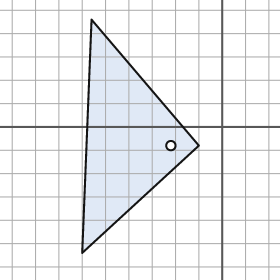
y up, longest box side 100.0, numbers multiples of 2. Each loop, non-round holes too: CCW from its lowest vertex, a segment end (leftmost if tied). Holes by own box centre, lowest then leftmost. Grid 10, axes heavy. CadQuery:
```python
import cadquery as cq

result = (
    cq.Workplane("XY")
    .moveTo(-60.0, -54.0)
    .lineTo(-10.0, -8.0)
    .lineTo(-56.0, 46.0)
    .close()
    .moveTo(-22.0, -8.0)
    .circle(2.0)
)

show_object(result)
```